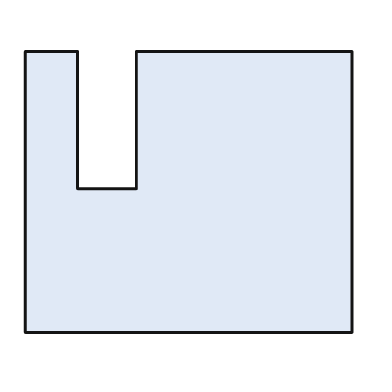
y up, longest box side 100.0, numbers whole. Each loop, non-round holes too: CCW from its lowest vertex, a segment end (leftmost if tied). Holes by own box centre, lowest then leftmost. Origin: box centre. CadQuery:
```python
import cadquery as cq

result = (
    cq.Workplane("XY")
    .moveTo(-50.0, -43.0)
    .lineTo(50.0, -43.0)
    .lineTo(50.0, 43.0)
    .lineTo(-16.0, 43.0)
    .lineTo(-16.0, 1.0)
    .lineTo(-34.0, 1.0)
    .lineTo(-34.0, 43.0)
    .lineTo(-50.0, 43.0)
    .close()
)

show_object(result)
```